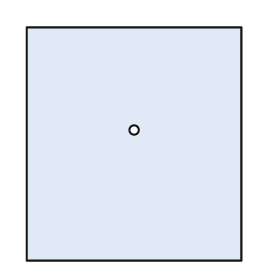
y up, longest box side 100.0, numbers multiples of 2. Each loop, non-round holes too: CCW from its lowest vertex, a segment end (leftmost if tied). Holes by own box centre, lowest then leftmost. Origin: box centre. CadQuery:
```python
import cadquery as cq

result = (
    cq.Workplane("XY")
    .moveTo(-46.0, -50.0)
    .lineTo(46.0, -50.0)
    .lineTo(46.0, 50.0)
    .lineTo(-46.0, 50.0)
    .close()
    .moveTo(0.0, 6.0)
    .circle(2.0)
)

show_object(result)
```